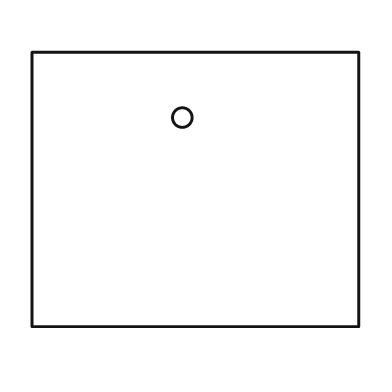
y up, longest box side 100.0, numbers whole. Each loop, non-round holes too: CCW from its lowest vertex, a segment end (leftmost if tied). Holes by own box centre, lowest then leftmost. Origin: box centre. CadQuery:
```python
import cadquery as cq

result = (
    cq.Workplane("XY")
    .moveTo(-50.0, -42.0)
    .lineTo(50.0, -42.0)
    .lineTo(50.0, 42.0)
    .lineTo(-50.0, 42.0)
    .close()
    .moveTo(-4.0, 22.0)
    .circle(3.0)
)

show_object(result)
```